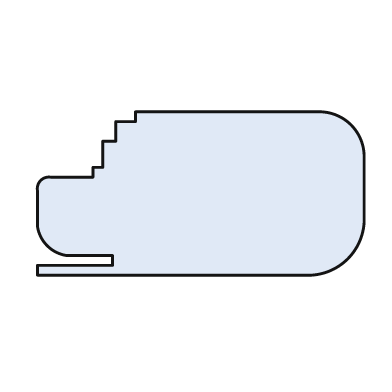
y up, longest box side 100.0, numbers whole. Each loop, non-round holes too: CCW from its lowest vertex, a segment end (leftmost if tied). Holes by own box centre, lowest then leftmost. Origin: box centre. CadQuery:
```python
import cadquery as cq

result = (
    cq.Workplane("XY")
    .moveTo(-50.0, -25.0)
    .lineTo(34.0, -25.0)
    .threePointArc((45.0, -20.0), (50.0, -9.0))
    .lineTo(50.0, 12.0)
    .threePointArc((46.0, 21.0), (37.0, 25.0))
    .lineTo(-20.0, 25.0)
    .lineTo(-20.0, 22.0)
    .lineTo(-26.0, 22.0)
    .lineTo(-26.0, 16.0)
    .lineTo(-30.0, 16.0)
    .lineTo(-30.0, 8.0)
    .lineTo(-33.0, 8.0)
    .lineTo(-33.0, 5.0)
    .lineTo(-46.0, 5.0)
    .threePointArc((-49.0, 4.0), (-50.0, 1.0))
    .lineTo(-50.0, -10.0)
    .threePointArc((-47.0, -16.0), (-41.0, -19.0))
    .lineTo(-27.0, -19.0)
    .lineTo(-27.0, -22.0)
    .lineTo(-50.0, -22.0)
    .close()
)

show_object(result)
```